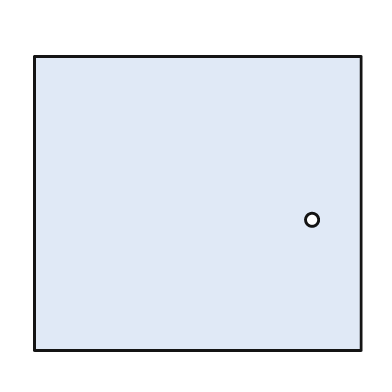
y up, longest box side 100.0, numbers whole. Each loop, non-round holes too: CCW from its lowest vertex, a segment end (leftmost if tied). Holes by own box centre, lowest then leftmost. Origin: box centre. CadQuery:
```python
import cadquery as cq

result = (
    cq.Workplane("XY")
    .moveTo(-50.0, -45.0)
    .lineTo(50.0, -45.0)
    .lineTo(50.0, 45.0)
    .lineTo(-50.0, 45.0)
    .close()
    .moveTo(35.0, -5.0)
    .circle(2.0)
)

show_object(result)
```